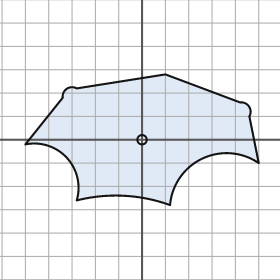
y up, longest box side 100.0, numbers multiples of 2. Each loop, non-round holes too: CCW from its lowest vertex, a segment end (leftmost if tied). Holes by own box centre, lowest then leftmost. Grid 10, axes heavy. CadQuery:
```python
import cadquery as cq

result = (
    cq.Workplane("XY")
    .moveTo(12.0, -28.0)
    .threePointArc((26.0, -8.0), (50.0, -10.0))
    .lineTo(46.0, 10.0)
    .threePointArc((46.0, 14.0), (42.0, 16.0))
    .lineTo(10.0, 28.0)
    .lineTo(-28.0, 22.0)
    .threePointArc((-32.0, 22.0), (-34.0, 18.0))
    .lineTo(-50.0, -2.0)
    .threePointArc((-32.0, -8.0), (-28.0, -26.0))
    .threePointArc((-8.0, -24.0), (12.0, -28.0))
    .close()
    .moveTo(0.0, 0.0)
    .circle(2.0)
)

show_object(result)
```